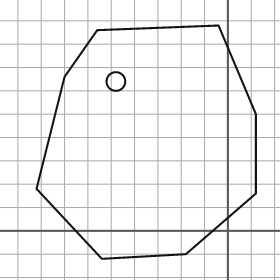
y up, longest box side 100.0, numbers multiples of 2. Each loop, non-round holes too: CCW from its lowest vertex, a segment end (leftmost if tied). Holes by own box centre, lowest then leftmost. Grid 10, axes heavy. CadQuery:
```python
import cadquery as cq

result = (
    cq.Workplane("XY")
    .moveTo(-54.0, -12.0)
    .lineTo(-18.0, -10.0)
    .lineTo(12.0, 16.0)
    .lineTo(12.0, 50.0)
    .lineTo(-4.0, 88.0)
    .lineTo(-56.0, 86.0)
    .lineTo(-70.0, 66.0)
    .lineTo(-82.0, 18.0)
    .close()
    .moveTo(-48.0, 64.0)
    .circle(4.0)
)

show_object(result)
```